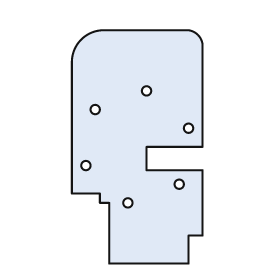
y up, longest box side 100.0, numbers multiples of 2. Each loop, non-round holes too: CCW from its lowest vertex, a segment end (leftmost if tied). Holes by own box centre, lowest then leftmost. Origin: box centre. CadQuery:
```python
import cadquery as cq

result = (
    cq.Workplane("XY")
    .moveTo(-12.0, -50.0)
    .lineTo(22.0, -50.0)
    .lineTo(22.0, -38.0)
    .lineTo(28.0, -38.0)
    .lineTo(28.0, -10.0)
    .lineTo(4.0, -10.0)
    .lineTo(4.0, 0.0)
    .lineTo(28.0, 0.0)
    .lineTo(28.0, 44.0)
    .threePointArc((26.0, 48.0), (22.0, 50.0))
    .lineTo(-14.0, 50.0)
    .threePointArc((-24.0, 46.0), (-28.0, 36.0))
    .lineTo(-28.0, -20.0)
    .lineTo(-16.0, -20.0)
    .lineTo(-16.0, -24.0)
    .lineTo(-12.0, -24.0)
    .close()
    .moveTo(-4.0, -24.0)
    .circle(2.0)
    .moveTo(18.0, -16.0)
    .circle(2.0)
    .moveTo(-22.0, -8.0)
    .circle(2.0)
    .moveTo(22.0, 8.0)
    .circle(2.0)
    .moveTo(-18.0, 16.0)
    .circle(2.0)
    .moveTo(4.0, 24.0)
    .circle(2.0)
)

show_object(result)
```